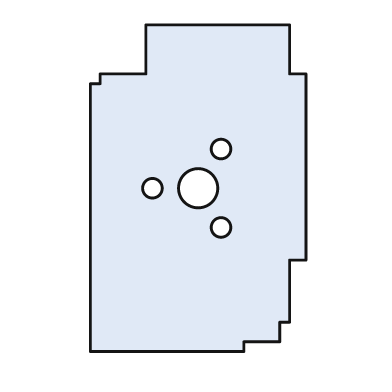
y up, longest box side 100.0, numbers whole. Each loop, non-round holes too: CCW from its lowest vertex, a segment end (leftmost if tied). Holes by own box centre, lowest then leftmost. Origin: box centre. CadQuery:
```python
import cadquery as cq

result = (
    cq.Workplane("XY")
    .moveTo(-33.0, -50.0)
    .lineTo(14.0, -50.0)
    .lineTo(14.0, -47.0)
    .lineTo(25.0, -47.0)
    .lineTo(25.0, -41.0)
    .lineTo(28.0, -41.0)
    .lineTo(28.0, -22.0)
    .lineTo(33.0, -22.0)
    .lineTo(33.0, 35.0)
    .lineTo(28.0, 35.0)
    .lineTo(28.0, 50.0)
    .lineTo(-16.0, 50.0)
    .lineTo(-16.0, 35.0)
    .lineTo(-30.0, 35.0)
    .lineTo(-30.0, 32.0)
    .lineTo(-33.0, 32.0)
    .close()
    .moveTo(7.0, -12.0)
    .circle(3.0)
    .moveTo(-14.0, 0.0)
    .circle(3.0)
    .moveTo(0.0, 0.0)
    .circle(6.0)
    .moveTo(7.0, 12.0)
    .circle(3.0)
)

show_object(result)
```